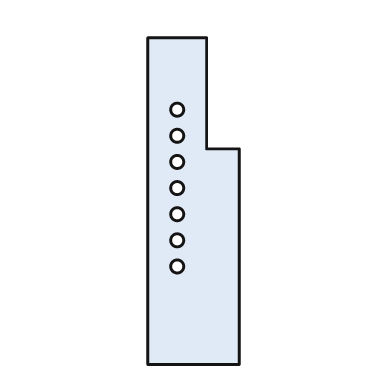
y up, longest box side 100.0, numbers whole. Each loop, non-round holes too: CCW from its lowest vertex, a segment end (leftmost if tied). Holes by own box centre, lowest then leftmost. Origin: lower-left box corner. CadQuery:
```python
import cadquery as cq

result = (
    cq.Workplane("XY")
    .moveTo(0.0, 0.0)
    .lineTo(28.0, 0.0)
    .lineTo(28.0, 66.0)
    .lineTo(18.0, 66.0)
    .lineTo(18.0, 100.0)
    .lineTo(0.0, 100.0)
    .close()
    .moveTo(9.0, 30.0)
    .circle(2.0)
    .moveTo(9.0, 38.0)
    .circle(2.0)
    .moveTo(9.0, 46.0)
    .circle(2.0)
    .moveTo(9.0, 54.0)
    .circle(2.0)
    .moveTo(9.0, 62.0)
    .circle(2.0)
    .moveTo(9.0, 70.0)
    .circle(2.0)
    .moveTo(9.0, 78.0)
    .circle(2.0)
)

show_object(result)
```